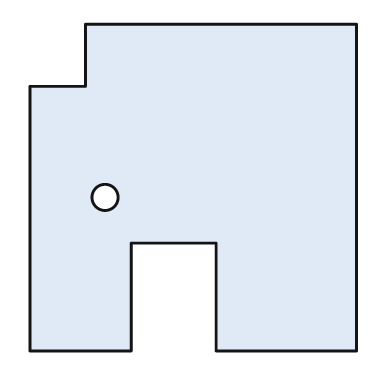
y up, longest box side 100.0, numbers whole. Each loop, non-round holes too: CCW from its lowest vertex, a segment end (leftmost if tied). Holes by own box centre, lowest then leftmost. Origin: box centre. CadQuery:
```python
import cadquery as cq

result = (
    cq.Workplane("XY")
    .moveTo(-50.0, -50.0)
    .lineTo(-19.0, -50.0)
    .lineTo(-19.0, -17.0)
    .lineTo(7.0, -17.0)
    .lineTo(7.0, -50.0)
    .lineTo(50.0, -50.0)
    .lineTo(50.0, 50.0)
    .lineTo(-33.0, 50.0)
    .lineTo(-33.0, 31.0)
    .lineTo(-50.0, 31.0)
    .close()
    .moveTo(-27.0, -3.0)
    .circle(4.0)
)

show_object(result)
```